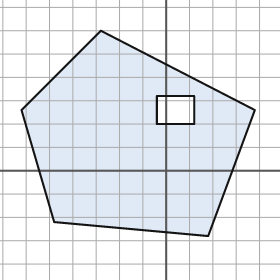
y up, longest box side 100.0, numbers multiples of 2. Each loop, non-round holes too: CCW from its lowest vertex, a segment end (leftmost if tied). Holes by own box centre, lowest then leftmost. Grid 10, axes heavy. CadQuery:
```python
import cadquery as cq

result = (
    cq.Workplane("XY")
    .moveTo(18.0, -28.0)
    .lineTo(38.0, 26.0)
    .lineTo(-28.0, 60.0)
    .lineTo(-62.0, 26.0)
    .lineTo(-48.0, -22.0)
    .close()
    .moveTo(-4.0, 20.0)
    .lineTo(12.0, 20.0)
    .lineTo(12.0, 32.0)
    .lineTo(-4.0, 32.0)
    .close()
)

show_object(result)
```